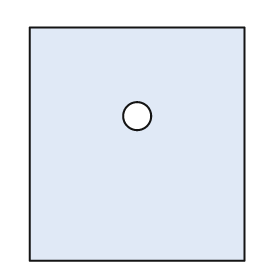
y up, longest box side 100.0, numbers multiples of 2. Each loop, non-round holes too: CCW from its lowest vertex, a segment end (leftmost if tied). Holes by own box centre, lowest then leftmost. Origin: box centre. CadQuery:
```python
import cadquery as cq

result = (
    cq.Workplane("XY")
    .moveTo(-46.0, -50.0)
    .lineTo(46.0, -50.0)
    .lineTo(46.0, 50.0)
    .lineTo(-46.0, 50.0)
    .close()
    .moveTo(0.0, 12.0)
    .circle(6.0)
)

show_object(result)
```